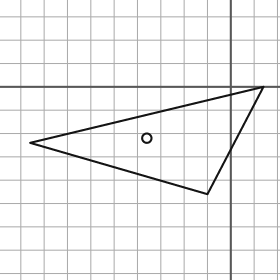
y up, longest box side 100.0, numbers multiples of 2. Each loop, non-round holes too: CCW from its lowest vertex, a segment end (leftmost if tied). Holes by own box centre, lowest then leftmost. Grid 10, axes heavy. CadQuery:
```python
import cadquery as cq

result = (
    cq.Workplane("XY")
    .moveTo(-10.0, -46.0)
    .lineTo(14.0, 0.0)
    .lineTo(-86.0, -24.0)
    .close()
    .moveTo(-36.0, -22.0)
    .circle(2.0)
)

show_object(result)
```